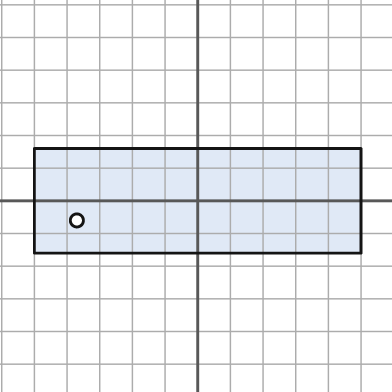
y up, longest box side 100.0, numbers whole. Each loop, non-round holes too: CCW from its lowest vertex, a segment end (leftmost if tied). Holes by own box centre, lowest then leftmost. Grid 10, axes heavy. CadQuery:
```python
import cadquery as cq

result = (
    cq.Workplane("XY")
    .moveTo(-50.0, -16.0)
    .lineTo(50.0, -16.0)
    .lineTo(50.0, 16.0)
    .lineTo(-50.0, 16.0)
    .close()
    .moveTo(-37.0, -6.0)
    .circle(2.0)
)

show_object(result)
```